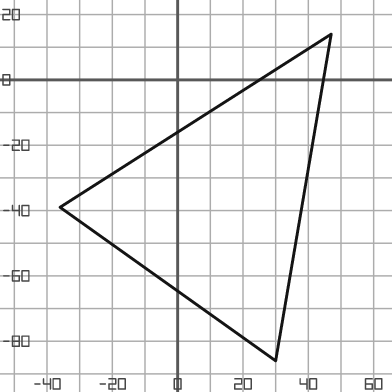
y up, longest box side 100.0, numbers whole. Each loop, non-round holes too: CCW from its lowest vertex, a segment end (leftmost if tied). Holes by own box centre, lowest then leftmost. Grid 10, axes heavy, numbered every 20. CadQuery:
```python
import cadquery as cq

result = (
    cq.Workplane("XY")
    .moveTo(30.0, -86.0)
    .lineTo(47.0, 14.0)
    .lineTo(-36.0, -39.0)
    .close()
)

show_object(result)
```